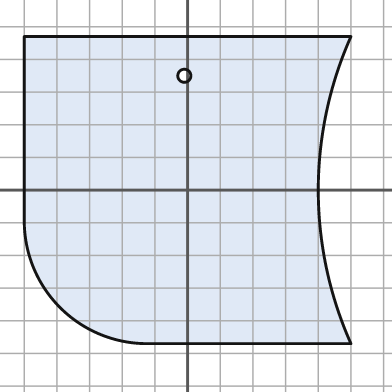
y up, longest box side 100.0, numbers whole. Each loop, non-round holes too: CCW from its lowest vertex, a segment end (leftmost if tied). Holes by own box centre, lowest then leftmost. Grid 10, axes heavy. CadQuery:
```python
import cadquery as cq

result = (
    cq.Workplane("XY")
    .moveTo(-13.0, -47.0)
    .lineTo(50.0, -47.0)
    .threePointArc((40.0, 0.0), (50.0, 47.0))
    .lineTo(-50.0, 47.0)
    .lineTo(-50.0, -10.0)
    .threePointArc((-39.0, -36.0), (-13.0, -47.0))
    .close()
    .moveTo(-1.0, 35.0)
    .circle(2.0)
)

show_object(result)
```